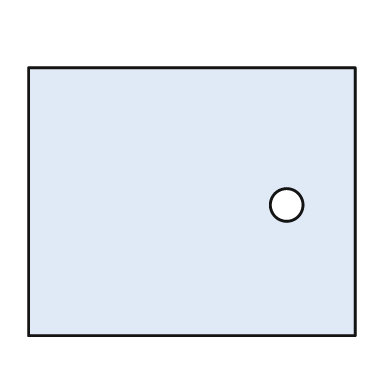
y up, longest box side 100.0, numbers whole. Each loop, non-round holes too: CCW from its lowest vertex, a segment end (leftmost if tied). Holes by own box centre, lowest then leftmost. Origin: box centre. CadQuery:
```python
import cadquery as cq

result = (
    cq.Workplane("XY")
    .moveTo(-50.0, -41.0)
    .lineTo(50.0, -41.0)
    .lineTo(50.0, 41.0)
    .lineTo(-50.0, 41.0)
    .close()
    .moveTo(29.0, -1.0)
    .circle(5.0)
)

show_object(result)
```